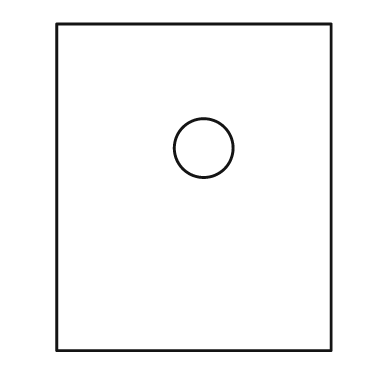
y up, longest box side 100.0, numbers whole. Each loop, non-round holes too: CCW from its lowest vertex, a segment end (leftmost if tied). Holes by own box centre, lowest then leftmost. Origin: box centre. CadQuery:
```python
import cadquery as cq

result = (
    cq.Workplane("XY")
    .moveTo(-42.0, -50.0)
    .lineTo(42.0, -50.0)
    .lineTo(42.0, 50.0)
    .lineTo(-42.0, 50.0)
    .close()
    .moveTo(3.0, 12.0)
    .circle(9.0)
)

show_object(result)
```